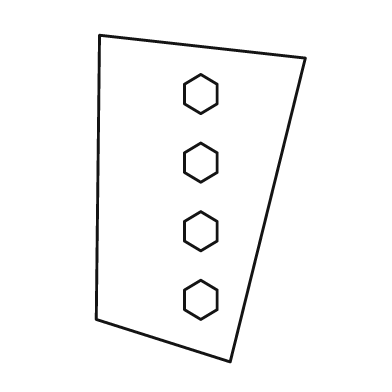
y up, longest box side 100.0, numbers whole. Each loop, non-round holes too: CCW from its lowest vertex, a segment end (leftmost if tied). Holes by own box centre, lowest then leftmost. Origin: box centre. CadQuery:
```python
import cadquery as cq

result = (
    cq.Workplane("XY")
    .moveTo(9.0, -50.0)
    .lineTo(32.0, 43.0)
    .lineTo(-31.0, 50.0)
    .lineTo(-32.0, -37.0)
    .close()
    .moveTo(0.0, -37.0)
    .lineTo(5.0, -34.0)
    .lineTo(5.0, -28.0)
    .lineTo(0.0, -25.0)
    .lineTo(-5.0, -28.0)
    .lineTo(-5.0, -34.0)
    .close()
    .moveTo(0.0, -16.0)
    .lineTo(5.0, -13.0)
    .lineTo(5.0, -7.0)
    .lineTo(0.0, -4.0)
    .lineTo(-5.0, -7.0)
    .lineTo(-5.0, -13.0)
    .close()
    .moveTo(0.0, 5.0)
    .lineTo(5.0, 8.0)
    .lineTo(5.0, 14.0)
    .lineTo(0.0, 17.0)
    .lineTo(-5.0, 14.0)
    .lineTo(-5.0, 8.0)
    .close()
    .moveTo(0.0, 26.0)
    .lineTo(5.0, 29.0)
    .lineTo(5.0, 35.0)
    .lineTo(0.0, 38.0)
    .lineTo(-5.0, 35.0)
    .lineTo(-5.0, 29.0)
    .close()
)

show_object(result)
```